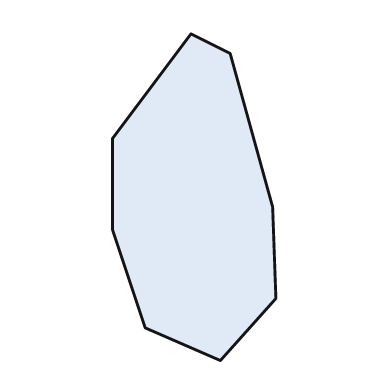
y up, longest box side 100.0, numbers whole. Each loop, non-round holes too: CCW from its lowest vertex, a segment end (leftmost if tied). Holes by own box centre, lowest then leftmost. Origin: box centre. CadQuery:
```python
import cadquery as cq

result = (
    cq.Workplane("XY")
    .moveTo(8.0, -50.0)
    .lineTo(25.0, -31.0)
    .lineTo(24.0, -3.0)
    .lineTo(11.0, 44.0)
    .lineTo(-1.0, 50.0)
    .lineTo(-25.0, 18.0)
    .lineTo(-25.0, -10.0)
    .lineTo(-15.0, -40.0)
    .close()
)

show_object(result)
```